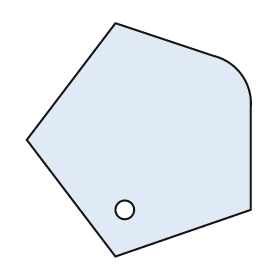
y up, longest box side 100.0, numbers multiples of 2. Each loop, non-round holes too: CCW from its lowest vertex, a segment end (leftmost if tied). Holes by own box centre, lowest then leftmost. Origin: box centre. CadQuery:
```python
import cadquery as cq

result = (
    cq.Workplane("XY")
    .moveTo(-10.0, -50.0)
    .lineTo(48.0, -30.0)
    .lineTo(48.0, 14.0)
    .threePointArc((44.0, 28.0), (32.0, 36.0))
    .lineTo(-10.0, 50.0)
    .lineTo(-48.0, 0.0)
    .close()
    .moveTo(-6.0, -30.0)
    .circle(4.0)
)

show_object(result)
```